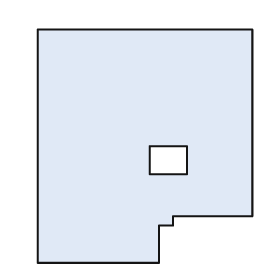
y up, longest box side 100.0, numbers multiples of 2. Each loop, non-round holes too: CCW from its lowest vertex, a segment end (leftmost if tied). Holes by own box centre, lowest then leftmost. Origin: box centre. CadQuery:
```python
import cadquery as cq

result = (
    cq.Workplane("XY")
    .moveTo(-46.0, -50.0)
    .lineTo(6.0, -50.0)
    .lineTo(6.0, -34.0)
    .lineTo(12.0, -34.0)
    .lineTo(12.0, -30.0)
    .lineTo(46.0, -30.0)
    .lineTo(46.0, 50.0)
    .lineTo(-46.0, 50.0)
    .close()
    .moveTo(2.0, -12.0)
    .lineTo(18.0, -12.0)
    .lineTo(18.0, 0.0)
    .lineTo(2.0, 0.0)
    .close()
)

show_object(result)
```